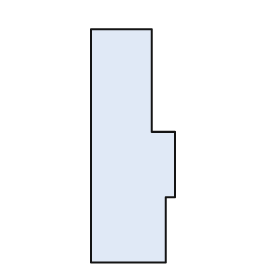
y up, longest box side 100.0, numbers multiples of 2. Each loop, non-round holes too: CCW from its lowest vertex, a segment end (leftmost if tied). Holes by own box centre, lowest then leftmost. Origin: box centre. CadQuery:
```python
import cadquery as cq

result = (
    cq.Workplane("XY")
    .moveTo(-18.0, -50.0)
    .lineTo(14.0, -50.0)
    .lineTo(14.0, -22.0)
    .lineTo(18.0, -22.0)
    .lineTo(18.0, 6.0)
    .lineTo(8.0, 6.0)
    .lineTo(8.0, 50.0)
    .lineTo(-18.0, 50.0)
    .close()
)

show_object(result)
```